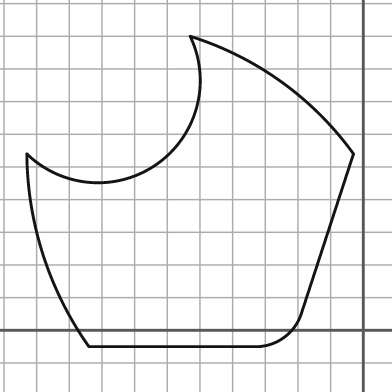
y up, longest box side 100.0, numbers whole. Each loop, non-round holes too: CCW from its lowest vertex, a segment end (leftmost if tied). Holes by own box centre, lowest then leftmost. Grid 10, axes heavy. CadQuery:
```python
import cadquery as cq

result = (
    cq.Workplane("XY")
    .moveTo(-84.0, -5.0)
    .lineTo(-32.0, -5.0)
    .threePointArc((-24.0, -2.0), (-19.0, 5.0))
    .lineTo(-3.0, 54.0)
    .threePointArc((-25.0, 76.0), (-53.0, 90.0))
    .threePointArc((-63.0, 51.0), (-103.0, 54.0))
    .threePointArc((-98.0, 23.0), (-84.0, -5.0))
    .close()
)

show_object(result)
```